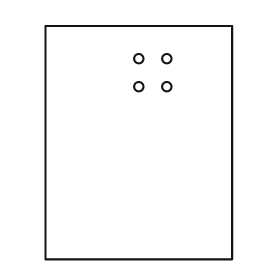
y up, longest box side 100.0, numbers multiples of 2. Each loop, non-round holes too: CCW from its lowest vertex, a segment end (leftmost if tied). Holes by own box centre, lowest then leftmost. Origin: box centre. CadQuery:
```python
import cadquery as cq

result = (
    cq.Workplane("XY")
    .moveTo(-40.0, -50.0)
    .lineTo(40.0, -50.0)
    .lineTo(40.0, 50.0)
    .lineTo(-40.0, 50.0)
    .close()
    .moveTo(0.0, 24.0)
    .circle(2.0)
    .moveTo(12.0, 24.0)
    .circle(2.0)
    .moveTo(0.0, 36.0)
    .circle(2.0)
    .moveTo(12.0, 36.0)
    .circle(2.0)
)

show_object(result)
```